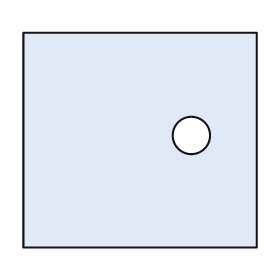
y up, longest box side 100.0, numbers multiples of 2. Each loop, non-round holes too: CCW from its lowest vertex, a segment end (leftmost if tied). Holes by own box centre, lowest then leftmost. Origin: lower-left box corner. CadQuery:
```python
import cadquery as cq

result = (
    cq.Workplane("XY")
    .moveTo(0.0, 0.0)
    .lineTo(100.0, 0.0)
    .lineTo(100.0, 92.0)
    .lineTo(0.0, 92.0)
    .close()
    .moveTo(72.0, 48.0)
    .circle(8.0)
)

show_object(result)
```